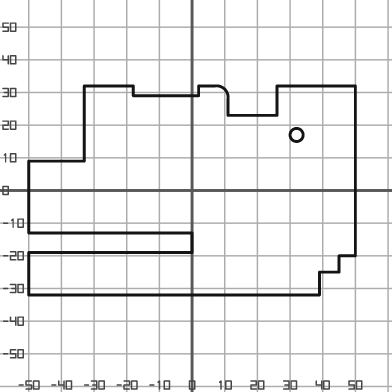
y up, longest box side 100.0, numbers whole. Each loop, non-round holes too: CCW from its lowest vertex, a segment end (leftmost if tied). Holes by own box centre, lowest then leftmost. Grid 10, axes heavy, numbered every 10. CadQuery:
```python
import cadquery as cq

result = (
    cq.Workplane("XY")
    .moveTo(-50.0, -32.0)
    .lineTo(39.0, -32.0)
    .lineTo(39.0, -25.0)
    .lineTo(45.0, -25.0)
    .lineTo(45.0, -20.0)
    .lineTo(50.0, -20.0)
    .lineTo(50.0, 32.0)
    .lineTo(26.0, 32.0)
    .lineTo(26.0, 23.0)
    .lineTo(11.0, 23.0)
    .lineTo(11.0, 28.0)
    .threePointArc((10.0, 31.0), (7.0, 32.0))
    .lineTo(2.0, 32.0)
    .lineTo(2.0, 29.0)
    .lineTo(-18.0, 29.0)
    .lineTo(-18.0, 32.0)
    .lineTo(-33.0, 32.0)
    .lineTo(-33.0, 9.0)
    .lineTo(-50.0, 9.0)
    .lineTo(-50.0, -13.0)
    .lineTo(0.0, -13.0)
    .lineTo(0.0, -19.0)
    .lineTo(-50.0, -19.0)
    .close()
    .moveTo(32.0, 17.0)
    .circle(2.0)
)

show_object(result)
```